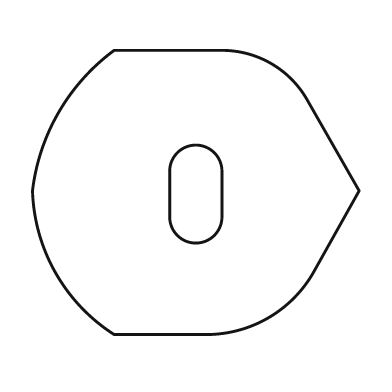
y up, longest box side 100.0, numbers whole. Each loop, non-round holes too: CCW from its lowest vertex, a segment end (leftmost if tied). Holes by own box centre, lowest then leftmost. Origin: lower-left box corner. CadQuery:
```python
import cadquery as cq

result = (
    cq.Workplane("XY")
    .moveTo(25.0, 0.0)
    .lineTo(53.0, 0.0)
    .threePointArc((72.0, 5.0), (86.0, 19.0))
    .lineTo(100.0, 44.0)
    .lineTo(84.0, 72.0)
    .threePointArc((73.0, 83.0), (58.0, 87.0))
    .lineTo(25.0, 87.0)
    .threePointArc((8.0, 68.0), (0.0, 44.0))
    .threePointArc((7.0, 19.0), (25.0, 0.0))
    .close()
    .moveTo(42.0, 36.0)
    .threePointArc((50.0, 28.0), (58.0, 36.0))
    .lineTo(58.0, 50.0)
    .threePointArc((50.0, 58.0), (42.0, 50.0))
    .close()
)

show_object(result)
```